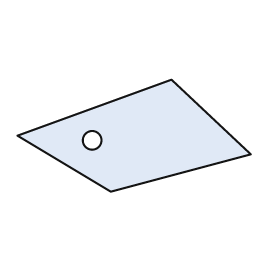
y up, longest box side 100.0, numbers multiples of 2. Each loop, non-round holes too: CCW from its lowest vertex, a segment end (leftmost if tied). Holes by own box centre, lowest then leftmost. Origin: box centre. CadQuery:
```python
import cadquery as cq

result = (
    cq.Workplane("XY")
    .moveTo(-10.0, -24.0)
    .lineTo(50.0, -8.0)
    .lineTo(16.0, 24.0)
    .lineTo(-50.0, 0.0)
    .close()
    .moveTo(-18.0, -2.0)
    .circle(4.0)
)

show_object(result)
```